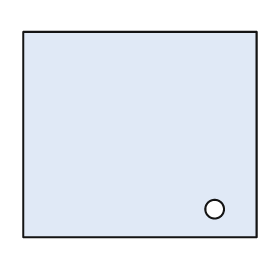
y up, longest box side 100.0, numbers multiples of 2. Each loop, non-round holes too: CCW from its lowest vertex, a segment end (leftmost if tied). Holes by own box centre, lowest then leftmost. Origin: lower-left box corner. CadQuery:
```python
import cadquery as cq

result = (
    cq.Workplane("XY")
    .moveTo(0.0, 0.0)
    .lineTo(100.0, 0.0)
    .lineTo(100.0, 88.0)
    .lineTo(0.0, 88.0)
    .close()
    .moveTo(82.0, 12.0)
    .circle(4.0)
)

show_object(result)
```